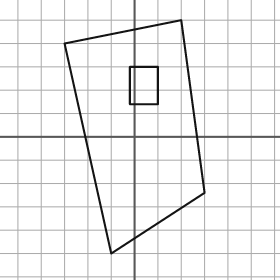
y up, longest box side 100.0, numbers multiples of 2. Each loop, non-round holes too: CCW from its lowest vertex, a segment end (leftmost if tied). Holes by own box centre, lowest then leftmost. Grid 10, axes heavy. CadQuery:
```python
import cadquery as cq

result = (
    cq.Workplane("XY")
    .moveTo(-10.0, -50.0)
    .lineTo(30.0, -24.0)
    .lineTo(20.0, 50.0)
    .lineTo(-30.0, 40.0)
    .close()
    .moveTo(-2.0, 14.0)
    .lineTo(10.0, 14.0)
    .lineTo(10.0, 30.0)
    .lineTo(-2.0, 30.0)
    .close()
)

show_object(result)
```